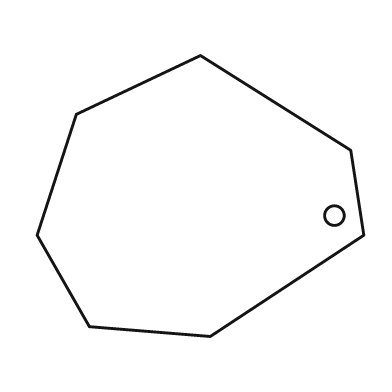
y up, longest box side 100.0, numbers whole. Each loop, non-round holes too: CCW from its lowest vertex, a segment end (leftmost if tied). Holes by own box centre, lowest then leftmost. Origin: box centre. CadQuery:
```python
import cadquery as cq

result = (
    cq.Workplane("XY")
    .moveTo(3.0, -43.0)
    .lineTo(50.0, -12.0)
    .lineTo(46.0, 14.0)
    .lineTo(0.0, 43.0)
    .lineTo(-38.0, 25.0)
    .lineTo(-50.0, -12.0)
    .lineTo(-34.0, -40.0)
    .close()
    .moveTo(41.0, -6.0)
    .circle(3.0)
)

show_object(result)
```